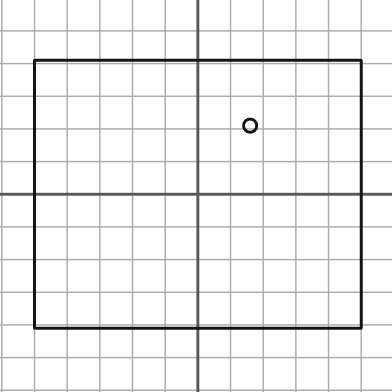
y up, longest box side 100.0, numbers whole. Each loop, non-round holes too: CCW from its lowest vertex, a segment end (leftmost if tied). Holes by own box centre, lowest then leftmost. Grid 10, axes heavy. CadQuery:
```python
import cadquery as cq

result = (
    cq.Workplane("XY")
    .moveTo(-50.0, -41.0)
    .lineTo(50.0, -41.0)
    .lineTo(50.0, 41.0)
    .lineTo(-50.0, 41.0)
    .close()
    .moveTo(16.0, 21.0)
    .circle(2.0)
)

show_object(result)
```